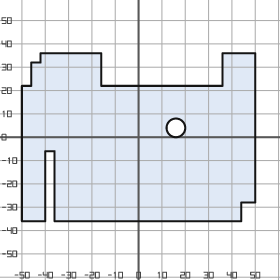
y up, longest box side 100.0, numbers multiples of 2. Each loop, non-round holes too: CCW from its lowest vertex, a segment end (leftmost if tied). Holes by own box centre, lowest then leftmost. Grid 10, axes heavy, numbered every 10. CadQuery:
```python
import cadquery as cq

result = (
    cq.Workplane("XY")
    .moveTo(-50.0, -36.0)
    .lineTo(-40.0, -36.0)
    .lineTo(-40.0, -6.0)
    .lineTo(-36.0, -6.0)
    .lineTo(-36.0, -36.0)
    .lineTo(44.0, -36.0)
    .lineTo(44.0, -28.0)
    .lineTo(50.0, -28.0)
    .lineTo(50.0, 36.0)
    .lineTo(36.0, 36.0)
    .lineTo(36.0, 22.0)
    .lineTo(-16.0, 22.0)
    .lineTo(-16.0, 36.0)
    .lineTo(-42.0, 36.0)
    .lineTo(-42.0, 32.0)
    .lineTo(-46.0, 32.0)
    .lineTo(-46.0, 22.0)
    .lineTo(-50.0, 22.0)
    .close()
    .moveTo(16.0, 4.0)
    .circle(4.0)
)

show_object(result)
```